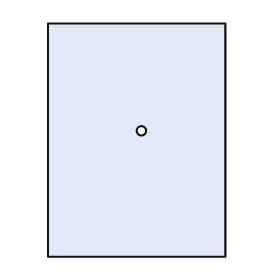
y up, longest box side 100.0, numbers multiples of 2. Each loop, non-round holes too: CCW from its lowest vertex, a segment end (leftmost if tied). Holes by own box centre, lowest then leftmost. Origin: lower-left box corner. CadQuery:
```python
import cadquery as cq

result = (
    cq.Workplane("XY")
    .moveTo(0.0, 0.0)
    .lineTo(76.0, 0.0)
    .lineTo(76.0, 100.0)
    .lineTo(0.0, 100.0)
    .close()
    .moveTo(40.0, 54.0)
    .circle(2.0)
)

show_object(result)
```